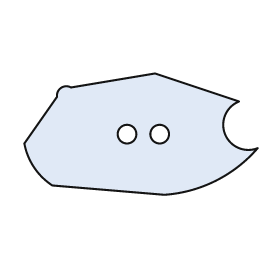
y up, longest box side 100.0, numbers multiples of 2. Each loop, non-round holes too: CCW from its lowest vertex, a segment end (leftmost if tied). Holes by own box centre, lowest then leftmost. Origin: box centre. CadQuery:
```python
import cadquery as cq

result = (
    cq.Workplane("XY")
    .moveTo(10.0, -26.0)
    .threePointArc((32.0, -20.0), (50.0, -6.0))
    .threePointArc((36.0, 0.0), (42.0, 14.0))
    .lineTo(6.0, 26.0)
    .lineTo(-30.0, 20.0)
    .threePointArc((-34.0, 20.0), (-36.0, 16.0))
    .lineTo(-50.0, -4.0)
    .threePointArc((-46.0, -14.0), (-38.0, -22.0))
    .close()
    .moveTo(-6.0, 0.0)
    .circle(4.0)
    .moveTo(8.0, 0.0)
    .circle(4.0)
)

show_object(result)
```